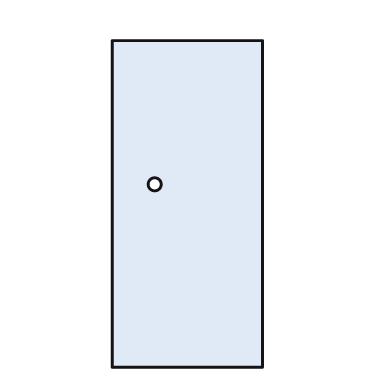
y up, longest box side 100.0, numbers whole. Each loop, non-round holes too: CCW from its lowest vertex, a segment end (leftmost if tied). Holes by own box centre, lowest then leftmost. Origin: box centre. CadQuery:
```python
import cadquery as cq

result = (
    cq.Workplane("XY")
    .moveTo(-23.0, -50.0)
    .lineTo(23.0, -50.0)
    .lineTo(23.0, 50.0)
    .lineTo(-23.0, 50.0)
    .close()
    .moveTo(-10.0, 6.0)
    .circle(2.0)
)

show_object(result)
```